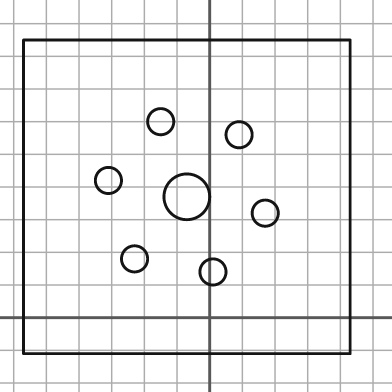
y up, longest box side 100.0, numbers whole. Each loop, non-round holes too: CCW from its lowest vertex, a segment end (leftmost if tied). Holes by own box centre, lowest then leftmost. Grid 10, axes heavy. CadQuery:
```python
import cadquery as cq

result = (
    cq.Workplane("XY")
    .moveTo(-57.0, -11.0)
    .lineTo(43.0, -11.0)
    .lineTo(43.0, 85.0)
    .lineTo(-57.0, 85.0)
    .close()
    .moveTo(1.0, 14.0)
    .circle(4.0)
    .moveTo(-23.0, 18.0)
    .circle(4.0)
    .moveTo(17.0, 32.0)
    .circle(4.0)
    .moveTo(-7.0, 37.0)
    .circle(7.0)
    .moveTo(-31.0, 42.0)
    .circle(4.0)
    .moveTo(9.0, 56.0)
    .circle(4.0)
    .moveTo(-15.0, 60.0)
    .circle(4.0)
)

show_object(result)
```